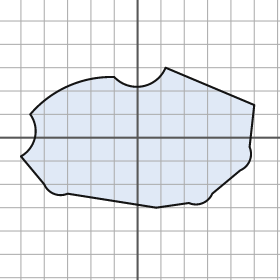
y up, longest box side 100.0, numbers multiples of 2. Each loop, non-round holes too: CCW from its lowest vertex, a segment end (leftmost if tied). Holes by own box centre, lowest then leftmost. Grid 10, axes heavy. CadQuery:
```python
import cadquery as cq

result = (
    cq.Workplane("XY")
    .moveTo(8.0, -30.0)
    .lineTo(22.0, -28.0)
    .threePointArc((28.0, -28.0), (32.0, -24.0))
    .lineTo(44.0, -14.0)
    .threePointArc((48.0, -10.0), (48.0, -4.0))
    .lineTo(50.0, 14.0)
    .lineTo(12.0, 30.0)
    .threePointArc((2.0, 22.0), (-10.0, 26.0))
    .threePointArc((-30.0, 22.0), (-46.0, 10.0))
    .threePointArc((-44.0, 0.0), (-50.0, -8.0))
    .lineTo(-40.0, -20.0)
    .threePointArc((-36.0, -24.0), (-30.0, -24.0))
    .close()
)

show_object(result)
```